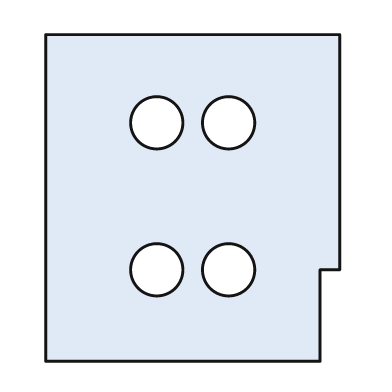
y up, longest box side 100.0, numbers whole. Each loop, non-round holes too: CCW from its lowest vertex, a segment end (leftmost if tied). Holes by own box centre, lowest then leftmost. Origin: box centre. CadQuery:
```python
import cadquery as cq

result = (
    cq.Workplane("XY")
    .moveTo(-45.0, -50.0)
    .lineTo(39.0, -50.0)
    .lineTo(39.0, -22.0)
    .lineTo(45.0, -22.0)
    .lineTo(45.0, 50.0)
    .lineTo(-45.0, 50.0)
    .close()
    .moveTo(-11.0, -22.0)
    .circle(8.0)
    .moveTo(11.0, -22.0)
    .circle(8.0)
    .moveTo(-11.0, 23.0)
    .circle(8.0)
    .moveTo(11.0, 23.0)
    .circle(8.0)
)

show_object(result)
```